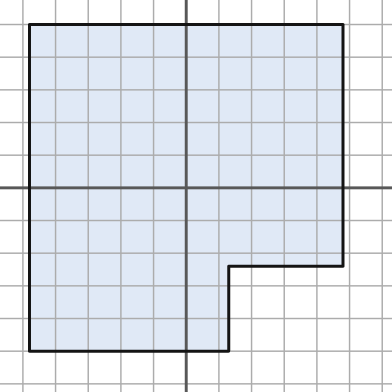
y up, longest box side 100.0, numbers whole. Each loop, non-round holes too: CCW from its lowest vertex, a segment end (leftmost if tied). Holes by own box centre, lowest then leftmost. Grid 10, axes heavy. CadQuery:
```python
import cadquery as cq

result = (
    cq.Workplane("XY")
    .moveTo(-48.0, -50.0)
    .lineTo(13.0, -50.0)
    .lineTo(13.0, -24.0)
    .lineTo(48.0, -24.0)
    .lineTo(48.0, 50.0)
    .lineTo(-48.0, 50.0)
    .close()
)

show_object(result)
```